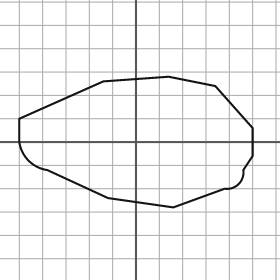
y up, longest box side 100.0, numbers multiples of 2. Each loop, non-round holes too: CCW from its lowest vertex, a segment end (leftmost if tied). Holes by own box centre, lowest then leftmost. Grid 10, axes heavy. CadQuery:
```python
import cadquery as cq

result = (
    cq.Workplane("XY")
    .moveTo(16.0, -28.0)
    .lineTo(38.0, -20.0)
    .threePointArc((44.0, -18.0), (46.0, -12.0))
    .lineTo(50.0, -6.0)
    .lineTo(50.0, 6.0)
    .lineTo(34.0, 24.0)
    .lineTo(14.0, 28.0)
    .lineTo(-14.0, 26.0)
    .lineTo(-50.0, 10.0)
    .lineTo(-50.0, 0.0)
    .threePointArc((-46.0, -8.0), (-38.0, -12.0))
    .lineTo(-12.0, -24.0)
    .close()
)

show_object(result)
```